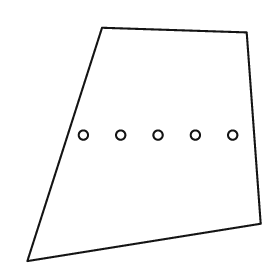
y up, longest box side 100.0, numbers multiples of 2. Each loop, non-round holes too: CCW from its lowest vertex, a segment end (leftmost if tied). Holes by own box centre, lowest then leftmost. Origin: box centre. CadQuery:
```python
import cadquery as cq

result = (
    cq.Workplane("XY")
    .moveTo(-50.0, -50.0)
    .lineTo(50.0, -34.0)
    .lineTo(44.0, 48.0)
    .lineTo(-18.0, 50.0)
    .close()
    .moveTo(-26.0, 4.0)
    .circle(2.0)
    .moveTo(-10.0, 4.0)
    .circle(2.0)
    .moveTo(6.0, 4.0)
    .circle(2.0)
    .moveTo(22.0, 4.0)
    .circle(2.0)
    .moveTo(38.0, 4.0)
    .circle(2.0)
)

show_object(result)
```